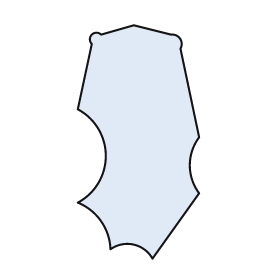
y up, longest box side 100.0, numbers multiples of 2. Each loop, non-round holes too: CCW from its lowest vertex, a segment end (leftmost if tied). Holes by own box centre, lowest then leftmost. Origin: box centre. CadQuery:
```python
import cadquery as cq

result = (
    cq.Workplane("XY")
    .moveTo(6.0, -50.0)
    .lineTo(26.0, -22.0)
    .threePointArc((22.0, -10.0), (26.0, 2.0))
    .lineTo(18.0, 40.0)
    .threePointArc((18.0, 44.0), (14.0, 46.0))
    .lineTo(-2.0, 50.0)
    .lineTo(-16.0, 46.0)
    .threePointArc((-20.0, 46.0), (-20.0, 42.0))
    .lineTo(-26.0, 14.0)
    .threePointArc((-14.0, -6.0), (-26.0, -26.0))
    .threePointArc((-16.0, -34.0), (-12.0, -46.0))
    .threePointArc((-2.0, -44.0), (6.0, -50.0))
    .close()
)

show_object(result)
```